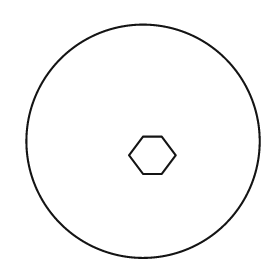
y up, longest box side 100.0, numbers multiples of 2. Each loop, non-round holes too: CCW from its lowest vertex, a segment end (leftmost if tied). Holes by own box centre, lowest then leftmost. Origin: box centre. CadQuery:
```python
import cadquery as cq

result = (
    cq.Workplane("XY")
    .moveTo(0.0, 0.0)
    .circle(50.0)
    .moveTo(0.0, -14.0)
    .lineTo(8.0, -14.0)
    .lineTo(14.0, -6.0)
    .lineTo(8.0, 2.0)
    .lineTo(0.0, 2.0)
    .lineTo(-6.0, -6.0)
    .close()
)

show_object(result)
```